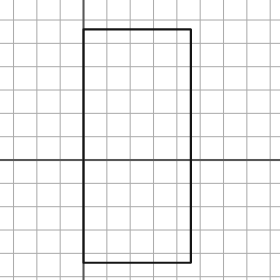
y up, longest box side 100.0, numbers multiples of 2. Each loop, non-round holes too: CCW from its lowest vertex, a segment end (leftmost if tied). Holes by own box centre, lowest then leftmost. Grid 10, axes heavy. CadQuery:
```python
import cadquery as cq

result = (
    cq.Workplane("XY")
    .moveTo(0.0, -44.0)
    .lineTo(46.0, -44.0)
    .lineTo(46.0, 56.0)
    .lineTo(0.0, 56.0)
    .close()
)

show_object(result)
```